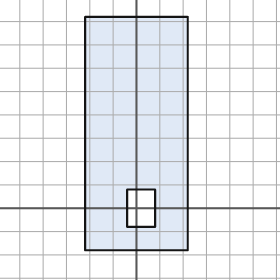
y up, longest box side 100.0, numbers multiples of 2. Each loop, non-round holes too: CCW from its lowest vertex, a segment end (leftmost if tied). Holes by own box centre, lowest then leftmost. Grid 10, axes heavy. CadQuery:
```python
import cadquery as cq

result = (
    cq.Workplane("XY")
    .moveTo(-22.0, -18.0)
    .lineTo(22.0, -18.0)
    .lineTo(22.0, 82.0)
    .lineTo(-22.0, 82.0)
    .close()
    .moveTo(-4.0, -8.0)
    .lineTo(8.0, -8.0)
    .lineTo(8.0, 8.0)
    .lineTo(-4.0, 8.0)
    .close()
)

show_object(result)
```